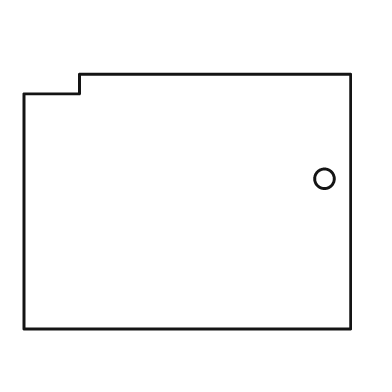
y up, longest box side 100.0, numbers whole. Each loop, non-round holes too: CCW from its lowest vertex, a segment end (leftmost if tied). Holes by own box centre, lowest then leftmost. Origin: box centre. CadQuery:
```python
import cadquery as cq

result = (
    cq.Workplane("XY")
    .moveTo(-50.0, -39.0)
    .lineTo(50.0, -39.0)
    .lineTo(50.0, 39.0)
    .lineTo(-33.0, 39.0)
    .lineTo(-33.0, 33.0)
    .lineTo(-50.0, 33.0)
    .close()
    .moveTo(42.0, 7.0)
    .circle(3.0)
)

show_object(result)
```